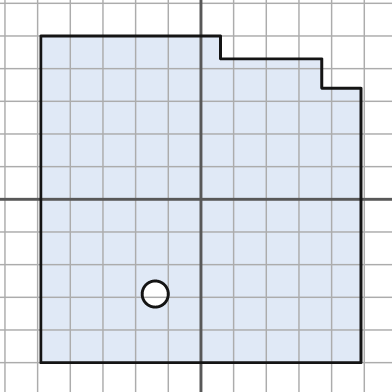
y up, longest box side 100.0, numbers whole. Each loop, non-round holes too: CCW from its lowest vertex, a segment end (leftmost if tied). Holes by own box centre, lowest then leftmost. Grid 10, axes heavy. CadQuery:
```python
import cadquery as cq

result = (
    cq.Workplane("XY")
    .moveTo(-49.0, -50.0)
    .lineTo(49.0, -50.0)
    .lineTo(49.0, 34.0)
    .lineTo(37.0, 34.0)
    .lineTo(37.0, 43.0)
    .lineTo(6.0, 43.0)
    .lineTo(6.0, 50.0)
    .lineTo(-49.0, 50.0)
    .close()
    .moveTo(-14.0, -29.0)
    .circle(4.0)
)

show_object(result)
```